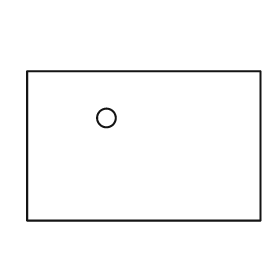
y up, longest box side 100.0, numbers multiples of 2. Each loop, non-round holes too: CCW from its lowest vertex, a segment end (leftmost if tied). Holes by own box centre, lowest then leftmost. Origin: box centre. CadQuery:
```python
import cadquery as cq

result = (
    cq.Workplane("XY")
    .moveTo(-50.0, -32.0)
    .lineTo(50.0, -32.0)
    .lineTo(50.0, 32.0)
    .lineTo(-50.0, 32.0)
    .close()
    .moveTo(-16.0, 12.0)
    .circle(4.0)
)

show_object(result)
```